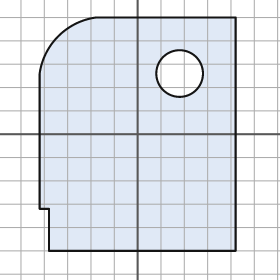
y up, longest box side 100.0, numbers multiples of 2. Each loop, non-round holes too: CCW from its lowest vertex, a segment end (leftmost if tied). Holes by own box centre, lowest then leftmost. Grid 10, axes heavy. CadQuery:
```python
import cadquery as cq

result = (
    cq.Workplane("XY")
    .moveTo(-38.0, -50.0)
    .lineTo(42.0, -50.0)
    .lineTo(42.0, 50.0)
    .lineTo(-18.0, 50.0)
    .threePointArc((-34.0, 42.0), (-42.0, 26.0))
    .lineTo(-42.0, -32.0)
    .lineTo(-38.0, -32.0)
    .close()
    .moveTo(18.0, 26.0)
    .circle(10.0)
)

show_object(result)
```